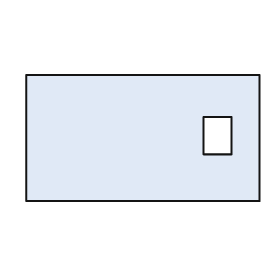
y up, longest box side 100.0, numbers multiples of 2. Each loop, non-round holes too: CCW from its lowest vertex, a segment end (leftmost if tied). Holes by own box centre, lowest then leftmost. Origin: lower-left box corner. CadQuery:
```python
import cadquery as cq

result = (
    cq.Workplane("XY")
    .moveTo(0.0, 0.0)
    .lineTo(100.0, 0.0)
    .lineTo(100.0, 54.0)
    .lineTo(0.0, 54.0)
    .close()
    .moveTo(76.0, 20.0)
    .lineTo(88.0, 20.0)
    .lineTo(88.0, 36.0)
    .lineTo(76.0, 36.0)
    .close()
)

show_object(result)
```